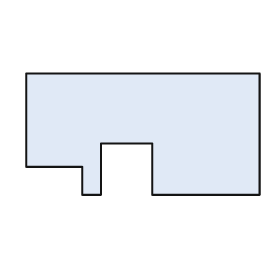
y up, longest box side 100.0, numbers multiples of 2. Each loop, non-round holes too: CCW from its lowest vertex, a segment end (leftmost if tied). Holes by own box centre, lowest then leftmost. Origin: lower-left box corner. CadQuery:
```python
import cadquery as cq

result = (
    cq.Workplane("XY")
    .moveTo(24.0, 0.0)
    .lineTo(32.0, 0.0)
    .lineTo(32.0, 22.0)
    .lineTo(54.0, 22.0)
    .lineTo(54.0, 0.0)
    .lineTo(100.0, 0.0)
    .lineTo(100.0, 52.0)
    .lineTo(0.0, 52.0)
    .lineTo(0.0, 12.0)
    .lineTo(24.0, 12.0)
    .close()
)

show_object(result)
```